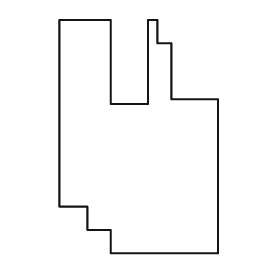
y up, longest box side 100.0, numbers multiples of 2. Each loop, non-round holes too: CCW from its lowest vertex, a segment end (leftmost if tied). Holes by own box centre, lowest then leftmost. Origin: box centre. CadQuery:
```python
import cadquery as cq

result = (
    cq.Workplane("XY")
    .moveTo(-12.0, -50.0)
    .lineTo(34.0, -50.0)
    .lineTo(34.0, 16.0)
    .lineTo(14.0, 16.0)
    .lineTo(14.0, 40.0)
    .lineTo(8.0, 40.0)
    .lineTo(8.0, 50.0)
    .lineTo(4.0, 50.0)
    .lineTo(4.0, 14.0)
    .lineTo(-12.0, 14.0)
    .lineTo(-12.0, 50.0)
    .lineTo(-34.0, 50.0)
    .lineTo(-34.0, -30.0)
    .lineTo(-22.0, -30.0)
    .lineTo(-22.0, -40.0)
    .lineTo(-12.0, -40.0)
    .close()
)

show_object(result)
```